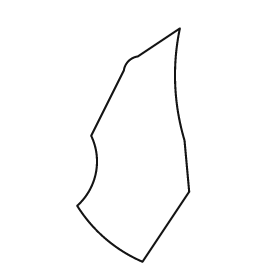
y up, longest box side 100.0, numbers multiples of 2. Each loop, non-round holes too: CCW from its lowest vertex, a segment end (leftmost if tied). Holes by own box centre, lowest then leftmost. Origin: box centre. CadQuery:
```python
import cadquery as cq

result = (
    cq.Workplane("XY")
    .moveTo(4.0, -50.0)
    .lineTo(24.0, -20.0)
    .lineTo(22.0, 2.0)
    .threePointArc((18.0, 26.0), (20.0, 50.0))
    .lineTo(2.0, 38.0)
    .threePointArc((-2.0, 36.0), (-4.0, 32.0))
    .lineTo(-18.0, 4.0)
    .threePointArc((-16.0, -12.0), (-24.0, -26.0))
    .threePointArc((-12.0, -40.0), (4.0, -50.0))
    .close()
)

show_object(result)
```